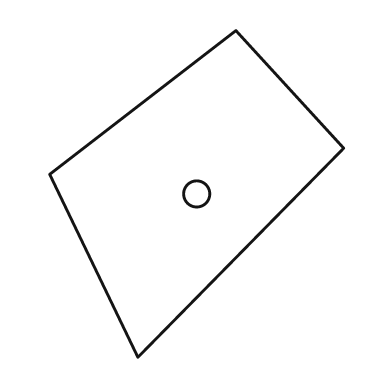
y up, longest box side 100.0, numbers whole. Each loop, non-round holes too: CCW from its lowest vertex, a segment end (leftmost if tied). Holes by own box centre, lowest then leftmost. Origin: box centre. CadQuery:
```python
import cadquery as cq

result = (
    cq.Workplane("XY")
    .moveTo(-18.0, -50.0)
    .lineTo(45.0, 14.0)
    .lineTo(12.0, 50.0)
    .lineTo(-45.0, 6.0)
    .close()
    .moveTo(0.0, 0.0)
    .circle(4.0)
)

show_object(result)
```